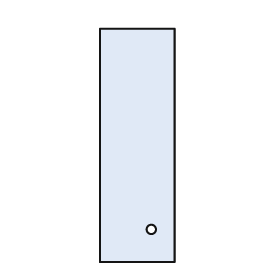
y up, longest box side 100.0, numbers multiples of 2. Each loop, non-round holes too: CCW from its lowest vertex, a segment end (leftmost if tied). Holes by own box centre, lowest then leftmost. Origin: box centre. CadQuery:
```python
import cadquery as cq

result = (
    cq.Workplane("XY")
    .moveTo(-16.0, -50.0)
    .lineTo(16.0, -50.0)
    .lineTo(16.0, 50.0)
    .lineTo(-16.0, 50.0)
    .close()
    .moveTo(6.0, -36.0)
    .circle(2.0)
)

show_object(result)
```